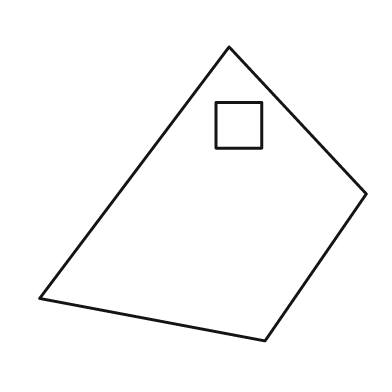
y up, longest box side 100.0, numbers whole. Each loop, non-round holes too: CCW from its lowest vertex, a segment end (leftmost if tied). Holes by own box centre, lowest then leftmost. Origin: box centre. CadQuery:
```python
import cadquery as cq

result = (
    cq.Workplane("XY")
    .moveTo(19.0, -45.0)
    .lineTo(50.0, 0.0)
    .lineTo(8.0, 45.0)
    .lineTo(-50.0, -32.0)
    .close()
    .moveTo(4.0, 14.0)
    .lineTo(18.0, 14.0)
    .lineTo(18.0, 28.0)
    .lineTo(4.0, 28.0)
    .close()
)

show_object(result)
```